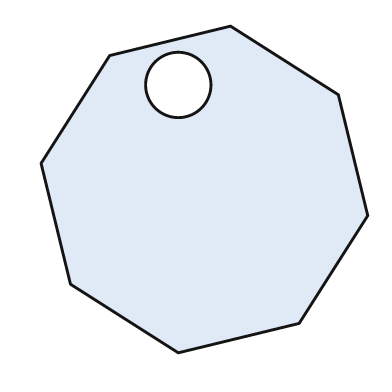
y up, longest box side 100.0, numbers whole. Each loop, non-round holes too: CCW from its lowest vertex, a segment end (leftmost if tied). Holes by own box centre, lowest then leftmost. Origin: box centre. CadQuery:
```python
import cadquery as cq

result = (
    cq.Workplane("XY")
    .moveTo(-8.0, -50.0)
    .lineTo(29.0, -41.0)
    .lineTo(50.0, -8.0)
    .lineTo(41.0, 29.0)
    .lineTo(8.0, 50.0)
    .lineTo(-29.0, 41.0)
    .lineTo(-50.0, 8.0)
    .lineTo(-41.0, -29.0)
    .close()
    .moveTo(-8.0, 32.0)
    .circle(10.0)
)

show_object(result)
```